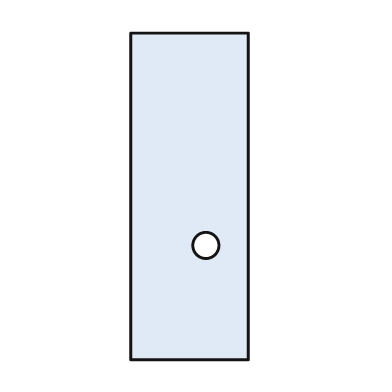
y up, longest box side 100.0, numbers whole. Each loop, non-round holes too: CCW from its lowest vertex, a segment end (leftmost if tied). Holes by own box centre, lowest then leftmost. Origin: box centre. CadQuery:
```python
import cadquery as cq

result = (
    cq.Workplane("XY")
    .moveTo(-18.0, -50.0)
    .lineTo(18.0, -50.0)
    .lineTo(18.0, 50.0)
    .lineTo(-18.0, 50.0)
    .close()
    .moveTo(5.0, -15.0)
    .circle(4.0)
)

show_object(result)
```